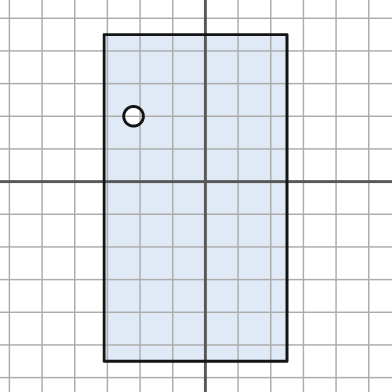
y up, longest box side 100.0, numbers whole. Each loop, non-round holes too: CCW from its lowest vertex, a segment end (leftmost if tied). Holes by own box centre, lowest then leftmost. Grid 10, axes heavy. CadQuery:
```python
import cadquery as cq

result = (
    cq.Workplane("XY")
    .moveTo(-31.0, -55.0)
    .lineTo(25.0, -55.0)
    .lineTo(25.0, 45.0)
    .lineTo(-31.0, 45.0)
    .close()
    .moveTo(-22.0, 20.0)
    .circle(3.0)
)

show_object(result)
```